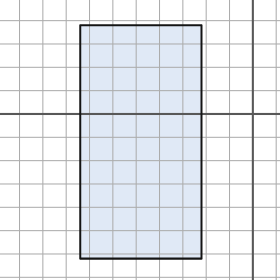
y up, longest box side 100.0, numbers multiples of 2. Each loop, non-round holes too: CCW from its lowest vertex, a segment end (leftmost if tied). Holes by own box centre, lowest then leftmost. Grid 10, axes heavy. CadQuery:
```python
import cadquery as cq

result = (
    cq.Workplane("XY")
    .moveTo(-74.0, -62.0)
    .lineTo(-22.0, -62.0)
    .lineTo(-22.0, 38.0)
    .lineTo(-74.0, 38.0)
    .close()
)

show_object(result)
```